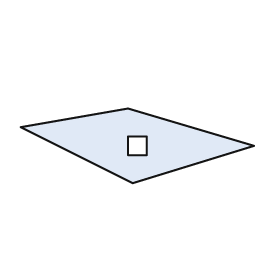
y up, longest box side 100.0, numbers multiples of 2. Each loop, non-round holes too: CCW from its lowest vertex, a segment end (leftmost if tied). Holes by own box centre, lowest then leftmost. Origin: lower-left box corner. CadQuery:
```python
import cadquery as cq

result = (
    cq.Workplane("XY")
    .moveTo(48.0, 0.0)
    .lineTo(100.0, 16.0)
    .lineTo(46.0, 32.0)
    .lineTo(0.0, 24.0)
    .close()
    .moveTo(46.0, 12.0)
    .lineTo(54.0, 12.0)
    .lineTo(54.0, 20.0)
    .lineTo(46.0, 20.0)
    .close()
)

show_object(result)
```